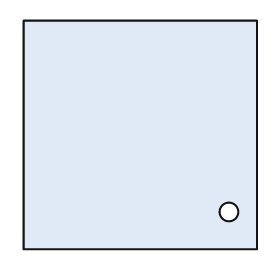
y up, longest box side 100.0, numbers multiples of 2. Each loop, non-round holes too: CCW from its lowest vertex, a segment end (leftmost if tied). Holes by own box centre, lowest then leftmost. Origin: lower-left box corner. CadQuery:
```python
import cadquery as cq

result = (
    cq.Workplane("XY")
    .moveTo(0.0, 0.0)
    .lineTo(100.0, 0.0)
    .lineTo(100.0, 98.0)
    .lineTo(0.0, 98.0)
    .close()
    .moveTo(88.0, 16.0)
    .circle(4.0)
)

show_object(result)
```